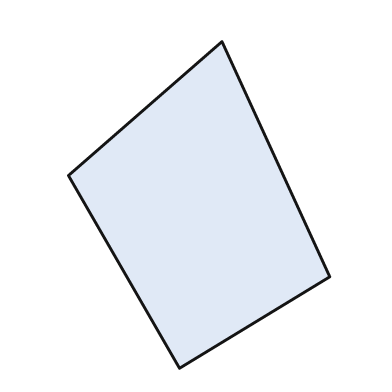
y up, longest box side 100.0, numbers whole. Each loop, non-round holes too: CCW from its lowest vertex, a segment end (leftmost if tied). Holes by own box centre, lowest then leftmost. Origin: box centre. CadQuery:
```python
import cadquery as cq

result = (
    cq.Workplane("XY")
    .moveTo(-6.0, -50.0)
    .lineTo(40.0, -22.0)
    .lineTo(7.0, 50.0)
    .lineTo(-40.0, 9.0)
    .close()
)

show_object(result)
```